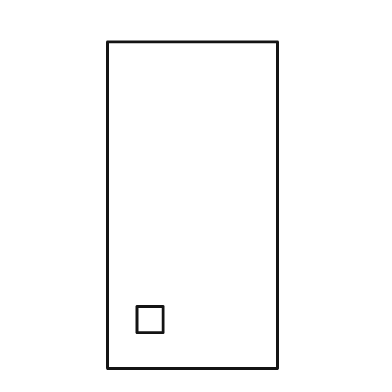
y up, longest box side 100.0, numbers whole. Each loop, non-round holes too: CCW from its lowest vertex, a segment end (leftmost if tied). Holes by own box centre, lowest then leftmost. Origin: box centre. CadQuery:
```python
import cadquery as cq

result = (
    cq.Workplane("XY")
    .moveTo(-26.0, -50.0)
    .lineTo(26.0, -50.0)
    .lineTo(26.0, 50.0)
    .lineTo(-26.0, 50.0)
    .close()
    .moveTo(-17.0, -39.0)
    .lineTo(-9.0, -39.0)
    .lineTo(-9.0, -31.0)
    .lineTo(-17.0, -31.0)
    .close()
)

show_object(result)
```